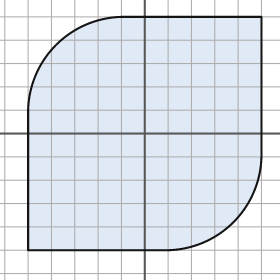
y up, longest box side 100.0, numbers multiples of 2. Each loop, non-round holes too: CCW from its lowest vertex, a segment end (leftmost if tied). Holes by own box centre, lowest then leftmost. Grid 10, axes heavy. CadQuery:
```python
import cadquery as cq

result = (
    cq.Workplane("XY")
    .moveTo(-50.0, -50.0)
    .lineTo(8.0, -50.0)
    .threePointArc((38.0, -38.0), (50.0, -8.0))
    .lineTo(50.0, 50.0)
    .lineTo(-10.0, 50.0)
    .threePointArc((-38.0, 38.0), (-50.0, 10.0))
    .close()
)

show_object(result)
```